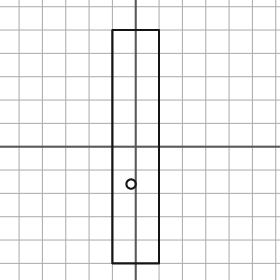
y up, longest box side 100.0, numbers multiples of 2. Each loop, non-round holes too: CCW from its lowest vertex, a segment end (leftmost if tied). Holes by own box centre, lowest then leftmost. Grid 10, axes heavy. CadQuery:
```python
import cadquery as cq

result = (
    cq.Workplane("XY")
    .moveTo(-10.0, -50.0)
    .lineTo(10.0, -50.0)
    .lineTo(10.0, 50.0)
    .lineTo(-10.0, 50.0)
    .close()
    .moveTo(-2.0, -16.0)
    .circle(2.0)
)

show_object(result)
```